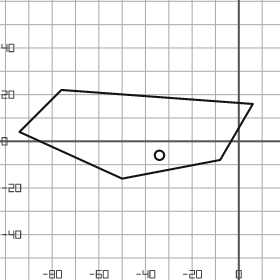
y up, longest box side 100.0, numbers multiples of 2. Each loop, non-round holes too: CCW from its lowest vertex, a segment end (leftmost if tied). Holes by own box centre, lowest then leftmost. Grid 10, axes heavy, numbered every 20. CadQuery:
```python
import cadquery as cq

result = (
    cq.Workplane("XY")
    .moveTo(-50.0, -16.0)
    .lineTo(-8.0, -8.0)
    .lineTo(6.0, 16.0)
    .lineTo(-76.0, 22.0)
    .lineTo(-94.0, 4.0)
    .close()
    .moveTo(-34.0, -6.0)
    .circle(2.0)
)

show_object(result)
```